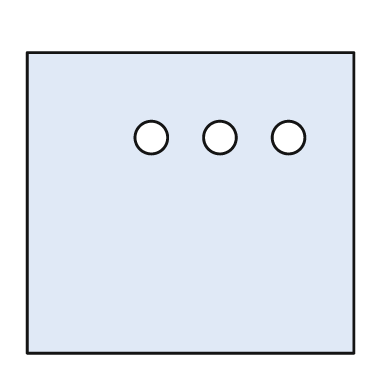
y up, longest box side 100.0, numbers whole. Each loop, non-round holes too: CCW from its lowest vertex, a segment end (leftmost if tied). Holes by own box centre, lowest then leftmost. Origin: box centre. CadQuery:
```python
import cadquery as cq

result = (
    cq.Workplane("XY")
    .moveTo(-50.0, -46.0)
    .lineTo(50.0, -46.0)
    .lineTo(50.0, 46.0)
    .lineTo(-50.0, 46.0)
    .close()
    .moveTo(-12.0, 20.0)
    .circle(5.0)
    .moveTo(9.0, 20.0)
    .circle(5.0)
    .moveTo(30.0, 20.0)
    .circle(5.0)
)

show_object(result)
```